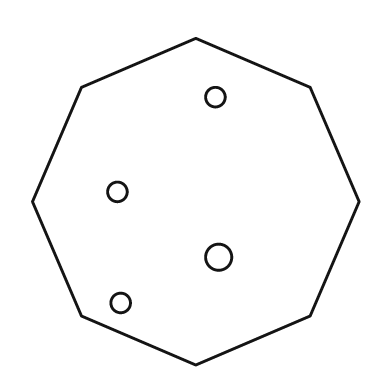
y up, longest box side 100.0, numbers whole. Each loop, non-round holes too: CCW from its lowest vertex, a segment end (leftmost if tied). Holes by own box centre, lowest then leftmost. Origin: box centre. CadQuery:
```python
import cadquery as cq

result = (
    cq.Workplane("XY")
    .moveTo(0.0, -50.0)
    .lineTo(35.0, -35.0)
    .lineTo(50.0, 0.0)
    .lineTo(35.0, 35.0)
    .lineTo(0.0, 50.0)
    .lineTo(-35.0, 35.0)
    .lineTo(-50.0, 0.0)
    .lineTo(-35.0, -35.0)
    .close()
    .moveTo(-23.0, -31.0)
    .circle(3.0)
    .moveTo(7.0, -17.0)
    .circle(4.0)
    .moveTo(-24.0, 3.0)
    .circle(3.0)
    .moveTo(6.0, 32.0)
    .circle(3.0)
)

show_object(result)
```